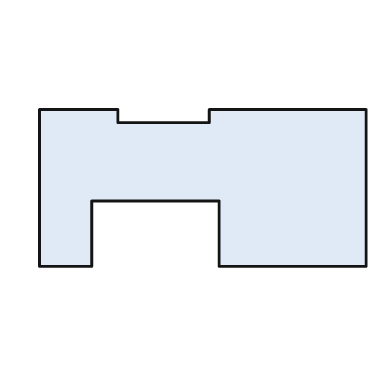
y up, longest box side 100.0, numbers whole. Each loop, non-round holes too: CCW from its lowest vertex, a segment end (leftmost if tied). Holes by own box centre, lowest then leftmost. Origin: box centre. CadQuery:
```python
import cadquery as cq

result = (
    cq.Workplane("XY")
    .moveTo(-50.0, -24.0)
    .lineTo(-34.0, -24.0)
    .lineTo(-34.0, -4.0)
    .lineTo(5.0, -4.0)
    .lineTo(5.0, -24.0)
    .lineTo(50.0, -24.0)
    .lineTo(50.0, 24.0)
    .lineTo(2.0, 24.0)
    .lineTo(2.0, 20.0)
    .lineTo(-26.0, 20.0)
    .lineTo(-26.0, 24.0)
    .lineTo(-50.0, 24.0)
    .close()
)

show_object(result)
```